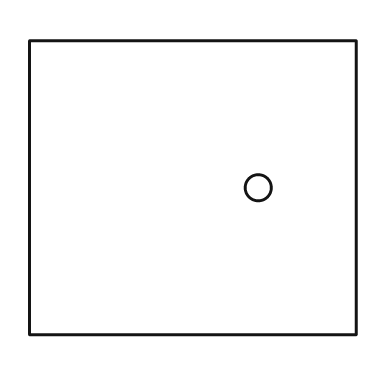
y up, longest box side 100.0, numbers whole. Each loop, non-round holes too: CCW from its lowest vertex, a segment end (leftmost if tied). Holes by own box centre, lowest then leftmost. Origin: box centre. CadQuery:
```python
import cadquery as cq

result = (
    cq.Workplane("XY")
    .moveTo(-50.0, -45.0)
    .lineTo(50.0, -45.0)
    .lineTo(50.0, 45.0)
    .lineTo(-50.0, 45.0)
    .close()
    .moveTo(20.0, 0.0)
    .circle(4.0)
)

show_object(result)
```